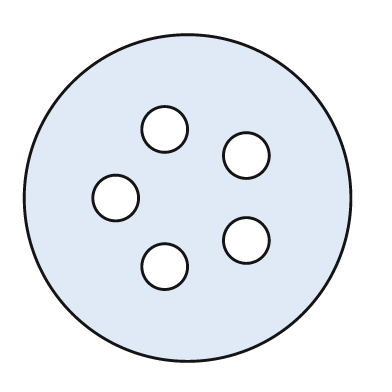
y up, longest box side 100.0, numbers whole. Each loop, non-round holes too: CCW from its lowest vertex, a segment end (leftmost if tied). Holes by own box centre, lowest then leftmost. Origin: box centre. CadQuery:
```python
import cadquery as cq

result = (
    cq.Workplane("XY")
    .moveTo(0.0, 0.0)
    .circle(50.0)
    .moveTo(-7.0, -21.0)
    .circle(7.0)
    .moveTo(18.0, -13.0)
    .circle(7.0)
    .moveTo(-22.0, 0.0)
    .circle(7.0)
    .moveTo(18.0, 13.0)
    .circle(7.0)
    .moveTo(-7.0, 21.0)
    .circle(7.0)
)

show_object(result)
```